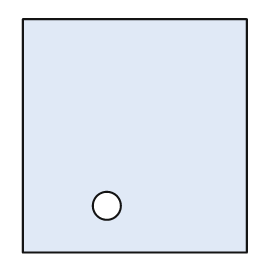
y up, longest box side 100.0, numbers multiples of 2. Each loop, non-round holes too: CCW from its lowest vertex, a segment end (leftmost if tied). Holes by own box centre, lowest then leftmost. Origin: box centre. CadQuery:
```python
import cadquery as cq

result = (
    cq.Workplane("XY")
    .moveTo(-48.0, -50.0)
    .lineTo(48.0, -50.0)
    .lineTo(48.0, 50.0)
    .lineTo(-48.0, 50.0)
    .close()
    .moveTo(-12.0, -30.0)
    .circle(6.0)
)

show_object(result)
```